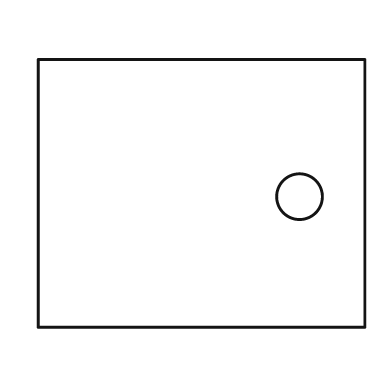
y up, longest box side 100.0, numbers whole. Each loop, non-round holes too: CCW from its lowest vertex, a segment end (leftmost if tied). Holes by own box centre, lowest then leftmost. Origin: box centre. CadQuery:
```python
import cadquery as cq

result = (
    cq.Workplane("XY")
    .moveTo(-50.0, -41.0)
    .lineTo(50.0, -41.0)
    .lineTo(50.0, 41.0)
    .lineTo(-50.0, 41.0)
    .close()
    .moveTo(30.0, -1.0)
    .circle(7.0)
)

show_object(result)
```